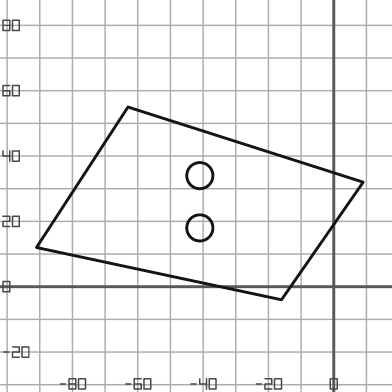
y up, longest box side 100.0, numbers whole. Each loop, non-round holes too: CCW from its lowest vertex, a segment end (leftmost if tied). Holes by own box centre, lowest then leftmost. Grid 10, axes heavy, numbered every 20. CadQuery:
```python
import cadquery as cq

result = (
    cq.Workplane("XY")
    .moveTo(-16.0, -4.0)
    .lineTo(9.0, 32.0)
    .lineTo(-63.0, 55.0)
    .lineTo(-91.0, 12.0)
    .close()
    .moveTo(-41.0, 18.0)
    .circle(4.0)
    .moveTo(-41.0, 34.0)
    .circle(4.0)
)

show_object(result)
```